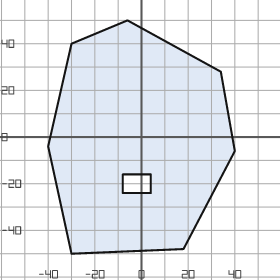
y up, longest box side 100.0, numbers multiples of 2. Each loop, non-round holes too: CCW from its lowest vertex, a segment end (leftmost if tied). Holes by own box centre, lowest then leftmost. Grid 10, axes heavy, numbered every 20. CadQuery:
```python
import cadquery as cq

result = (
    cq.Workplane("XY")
    .moveTo(-30.0, -50.0)
    .lineTo(18.0, -48.0)
    .lineTo(40.0, -6.0)
    .lineTo(34.0, 28.0)
    .lineTo(-6.0, 50.0)
    .lineTo(-30.0, 40.0)
    .lineTo(-40.0, -4.0)
    .close()
    .moveTo(-8.0, -24.0)
    .lineTo(4.0, -24.0)
    .lineTo(4.0, -16.0)
    .lineTo(-8.0, -16.0)
    .close()
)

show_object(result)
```